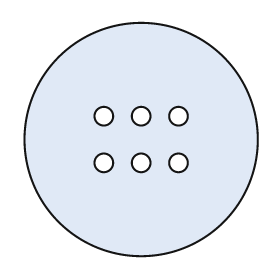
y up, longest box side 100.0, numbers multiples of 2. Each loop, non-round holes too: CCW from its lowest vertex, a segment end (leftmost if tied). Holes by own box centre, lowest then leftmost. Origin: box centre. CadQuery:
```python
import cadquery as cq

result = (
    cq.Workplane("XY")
    .moveTo(0.0, 0.0)
    .circle(50.0)
    .moveTo(-16.0, -10.0)
    .circle(4.0)
    .moveTo(0.0, -10.0)
    .circle(4.0)
    .moveTo(16.0, -10.0)
    .circle(4.0)
    .moveTo(-16.0, 10.0)
    .circle(4.0)
    .moveTo(0.0, 10.0)
    .circle(4.0)
    .moveTo(16.0, 10.0)
    .circle(4.0)
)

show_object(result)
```